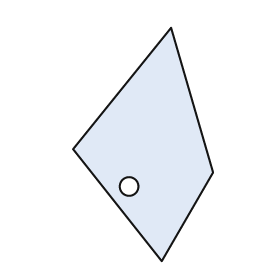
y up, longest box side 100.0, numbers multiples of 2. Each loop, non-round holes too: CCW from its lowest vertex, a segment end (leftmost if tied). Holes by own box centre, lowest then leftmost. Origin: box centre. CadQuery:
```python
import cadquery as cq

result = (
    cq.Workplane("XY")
    .moveTo(8.0, -50.0)
    .lineTo(30.0, -12.0)
    .lineTo(12.0, 50.0)
    .lineTo(-30.0, -2.0)
    .close()
    .moveTo(-6.0, -18.0)
    .circle(4.0)
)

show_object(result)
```